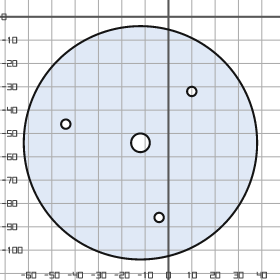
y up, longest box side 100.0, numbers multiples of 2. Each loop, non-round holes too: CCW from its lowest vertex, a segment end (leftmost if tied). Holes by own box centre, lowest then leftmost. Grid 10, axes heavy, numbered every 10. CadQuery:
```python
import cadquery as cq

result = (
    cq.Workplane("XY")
    .moveTo(-12.0, -54.0)
    .circle(50.0)
    .moveTo(-4.0, -86.0)
    .circle(2.0)
    .moveTo(-12.0, -54.0)
    .circle(4.0)
    .moveTo(-44.0, -46.0)
    .circle(2.0)
    .moveTo(10.0, -32.0)
    .circle(2.0)
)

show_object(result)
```